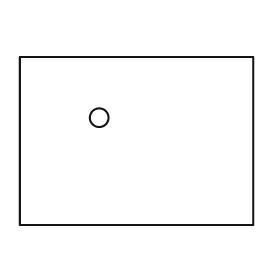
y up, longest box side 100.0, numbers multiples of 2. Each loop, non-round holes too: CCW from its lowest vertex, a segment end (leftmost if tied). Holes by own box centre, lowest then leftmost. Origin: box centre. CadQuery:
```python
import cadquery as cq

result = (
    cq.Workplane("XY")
    .moveTo(-50.0, -36.0)
    .lineTo(50.0, -36.0)
    .lineTo(50.0, 36.0)
    .lineTo(-50.0, 36.0)
    .close()
    .moveTo(-16.0, 10.0)
    .circle(4.0)
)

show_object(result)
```